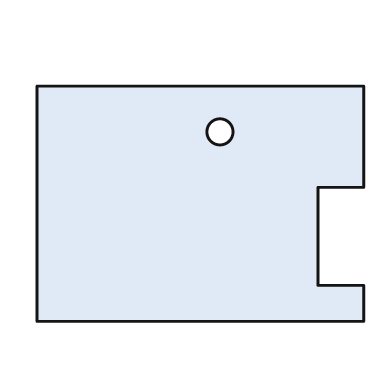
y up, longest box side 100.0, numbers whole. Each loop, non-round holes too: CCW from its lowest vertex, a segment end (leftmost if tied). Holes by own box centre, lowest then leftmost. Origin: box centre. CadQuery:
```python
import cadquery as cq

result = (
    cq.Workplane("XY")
    .moveTo(-50.0, -36.0)
    .lineTo(50.0, -36.0)
    .lineTo(50.0, -25.0)
    .lineTo(36.0, -25.0)
    .lineTo(36.0, 5.0)
    .lineTo(50.0, 5.0)
    .lineTo(50.0, 36.0)
    .lineTo(-50.0, 36.0)
    .close()
    .moveTo(6.0, 22.0)
    .circle(4.0)
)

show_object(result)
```